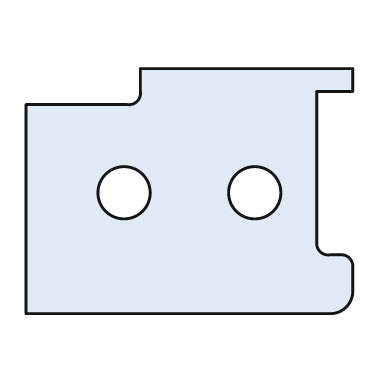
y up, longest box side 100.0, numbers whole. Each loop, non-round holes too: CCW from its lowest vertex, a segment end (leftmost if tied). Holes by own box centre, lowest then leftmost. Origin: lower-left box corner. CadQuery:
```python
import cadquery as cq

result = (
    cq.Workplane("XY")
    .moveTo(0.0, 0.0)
    .lineTo(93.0, 0.0)
    .threePointArc((98.0, 2.0), (100.0, 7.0))
    .lineTo(100.0, 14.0)
    .threePointArc((99.0, 17.0), (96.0, 18.0))
    .lineTo(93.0, 18.0)
    .threePointArc((90.0, 19.0), (89.0, 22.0))
    .lineTo(89.0, 68.0)
    .lineTo(100.0, 68.0)
    .lineTo(100.0, 75.0)
    .lineTo(35.0, 75.0)
    .lineTo(35.0, 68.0)
    .threePointArc((34.0, 65.0), (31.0, 64.0))
    .lineTo(0.0, 64.0)
    .close()
    .moveTo(30.0, 37.0)
    .circle(8.0)
    .moveTo(70.0, 37.0)
    .circle(8.0)
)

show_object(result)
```